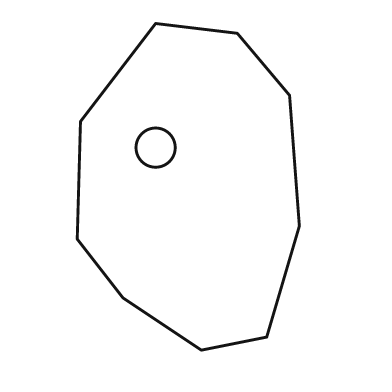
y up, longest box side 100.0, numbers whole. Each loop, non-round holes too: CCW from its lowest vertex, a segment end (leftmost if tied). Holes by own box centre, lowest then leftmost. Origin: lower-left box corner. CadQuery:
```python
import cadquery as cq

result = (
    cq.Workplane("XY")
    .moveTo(38.0, 0.0)
    .lineTo(58.0, 4.0)
    .lineTo(68.0, 38.0)
    .lineTo(65.0, 78.0)
    .lineTo(49.0, 97.0)
    .lineTo(24.0, 100.0)
    .lineTo(1.0, 70.0)
    .lineTo(0.0, 34.0)
    .lineTo(14.0, 16.0)
    .close()
    .moveTo(24.0, 62.0)
    .circle(6.0)
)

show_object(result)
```